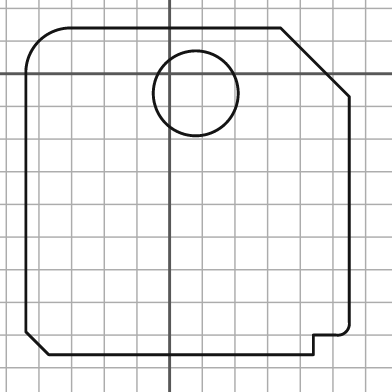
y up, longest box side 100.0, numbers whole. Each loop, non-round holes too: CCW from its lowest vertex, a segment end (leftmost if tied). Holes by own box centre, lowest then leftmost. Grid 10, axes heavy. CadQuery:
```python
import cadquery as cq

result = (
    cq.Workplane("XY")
    .moveTo(-37.0, -86.0)
    .lineTo(44.0, -86.0)
    .lineTo(44.0, -80.0)
    .lineTo(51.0, -80.0)
    .threePointArc((54.0, -79.0), (55.0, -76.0))
    .lineTo(55.0, -7.0)
    .lineTo(34.0, 14.0)
    .lineTo(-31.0, 14.0)
    .threePointArc((-40.0, 10.0), (-44.0, 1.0))
    .lineTo(-44.0, -79.0)
    .close()
    .moveTo(8.0, -6.0)
    .circle(13.0)
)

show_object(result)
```